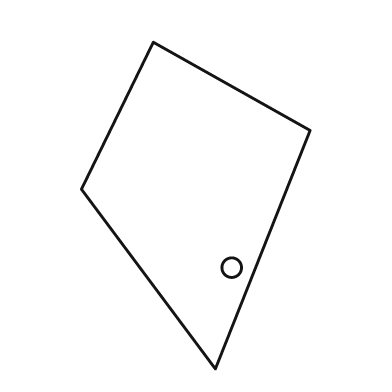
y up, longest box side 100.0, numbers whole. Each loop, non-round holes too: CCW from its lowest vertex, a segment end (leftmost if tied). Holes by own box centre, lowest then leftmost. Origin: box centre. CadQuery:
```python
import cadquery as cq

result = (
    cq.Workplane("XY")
    .moveTo(6.0, -50.0)
    .lineTo(35.0, 23.0)
    .lineTo(-13.0, 50.0)
    .lineTo(-35.0, 5.0)
    .close()
    .moveTo(11.0, -19.0)
    .circle(3.0)
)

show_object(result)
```